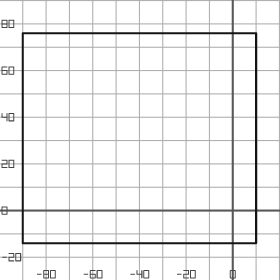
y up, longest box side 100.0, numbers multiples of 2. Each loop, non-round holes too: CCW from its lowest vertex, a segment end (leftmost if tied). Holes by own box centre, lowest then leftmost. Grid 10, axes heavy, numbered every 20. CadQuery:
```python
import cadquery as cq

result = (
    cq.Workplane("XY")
    .moveTo(-90.0, -14.0)
    .lineTo(10.0, -14.0)
    .lineTo(10.0, 76.0)
    .lineTo(-90.0, 76.0)
    .close()
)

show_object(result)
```